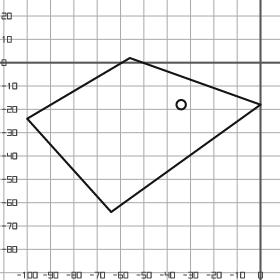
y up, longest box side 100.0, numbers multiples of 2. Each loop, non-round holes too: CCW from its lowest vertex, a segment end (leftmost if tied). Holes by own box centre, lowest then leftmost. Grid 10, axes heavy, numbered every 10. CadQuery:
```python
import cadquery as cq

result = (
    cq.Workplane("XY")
    .moveTo(-64.0, -64.0)
    .lineTo(0.0, -18.0)
    .lineTo(-56.0, 2.0)
    .lineTo(-100.0, -24.0)
    .close()
    .moveTo(-34.0, -18.0)
    .circle(2.0)
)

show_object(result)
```